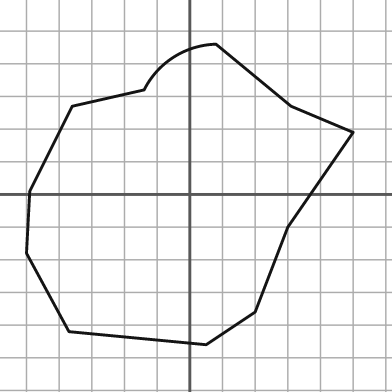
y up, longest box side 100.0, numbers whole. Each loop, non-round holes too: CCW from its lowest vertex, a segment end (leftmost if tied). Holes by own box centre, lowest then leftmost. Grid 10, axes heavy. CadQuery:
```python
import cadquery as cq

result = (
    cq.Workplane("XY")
    .moveTo(5.0, -46.0)
    .lineTo(20.0, -36.0)
    .lineTo(30.0, -10.0)
    .lineTo(50.0, 19.0)
    .lineTo(31.0, 27.0)
    .lineTo(8.0, 46.0)
    .threePointArc((-5.0, 42.0), (-14.0, 32.0))
    .lineTo(-36.0, 27.0)
    .lineTo(-49.0, 1.0)
    .lineTo(-50.0, -18.0)
    .lineTo(-37.0, -42.0)
    .close()
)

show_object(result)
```